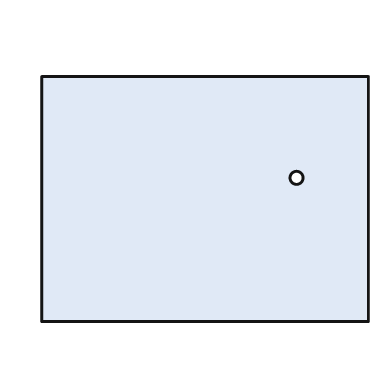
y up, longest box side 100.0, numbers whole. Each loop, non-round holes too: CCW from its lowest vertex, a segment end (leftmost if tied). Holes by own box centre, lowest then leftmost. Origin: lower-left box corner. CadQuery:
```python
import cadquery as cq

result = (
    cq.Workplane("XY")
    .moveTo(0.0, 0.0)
    .lineTo(100.0, 0.0)
    .lineTo(100.0, 75.0)
    .lineTo(0.0, 75.0)
    .close()
    .moveTo(78.0, 44.0)
    .circle(2.0)
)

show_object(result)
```